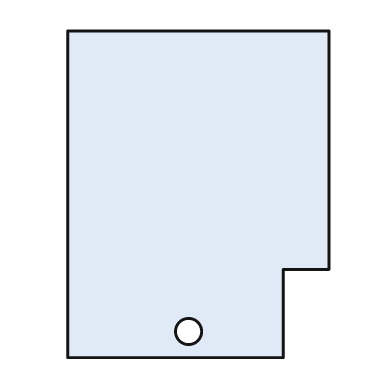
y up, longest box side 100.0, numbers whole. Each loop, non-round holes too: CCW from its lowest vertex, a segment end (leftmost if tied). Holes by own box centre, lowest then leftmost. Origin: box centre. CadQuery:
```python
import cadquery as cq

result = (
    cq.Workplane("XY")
    .moveTo(-40.0, -50.0)
    .lineTo(26.0, -50.0)
    .lineTo(26.0, -23.0)
    .lineTo(40.0, -23.0)
    .lineTo(40.0, 50.0)
    .lineTo(-40.0, 50.0)
    .close()
    .moveTo(-3.0, -42.0)
    .circle(4.0)
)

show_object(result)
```